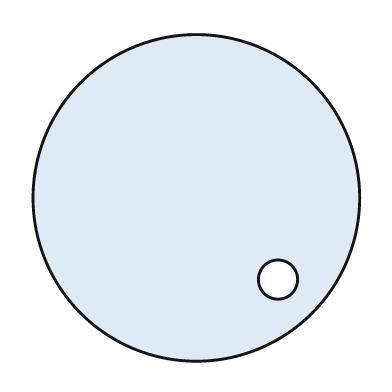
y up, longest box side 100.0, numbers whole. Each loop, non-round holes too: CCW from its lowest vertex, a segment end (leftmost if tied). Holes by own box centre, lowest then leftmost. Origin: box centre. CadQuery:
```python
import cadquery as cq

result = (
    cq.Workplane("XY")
    .moveTo(0.0, 0.0)
    .circle(50.0)
    .moveTo(25.0, -25.0)
    .circle(6.0)
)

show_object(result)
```